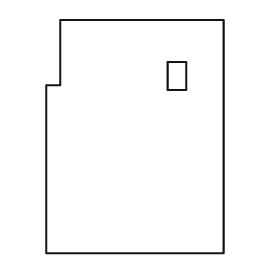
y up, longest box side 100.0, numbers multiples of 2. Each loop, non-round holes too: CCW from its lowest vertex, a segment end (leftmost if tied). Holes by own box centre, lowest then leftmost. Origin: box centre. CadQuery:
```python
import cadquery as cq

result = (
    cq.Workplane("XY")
    .moveTo(-38.0, -50.0)
    .lineTo(38.0, -50.0)
    .lineTo(38.0, 50.0)
    .lineTo(-32.0, 50.0)
    .lineTo(-32.0, 22.0)
    .lineTo(-38.0, 22.0)
    .close()
    .moveTo(14.0, 20.0)
    .lineTo(22.0, 20.0)
    .lineTo(22.0, 32.0)
    .lineTo(14.0, 32.0)
    .close()
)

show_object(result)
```